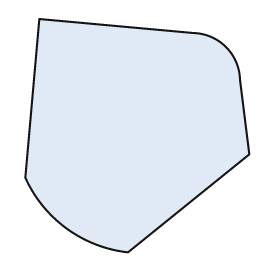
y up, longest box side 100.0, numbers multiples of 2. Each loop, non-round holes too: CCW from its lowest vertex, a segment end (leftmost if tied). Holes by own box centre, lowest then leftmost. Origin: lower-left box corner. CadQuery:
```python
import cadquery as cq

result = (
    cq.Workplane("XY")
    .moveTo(44.0, 0.0)
    .lineTo(96.0, 42.0)
    .lineTo(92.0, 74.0)
    .threePointArc((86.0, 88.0), (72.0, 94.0))
    .lineTo(6.0, 100.0)
    .lineTo(0.0, 32.0)
    .threePointArc((18.0, 10.0), (44.0, 0.0))
    .close()
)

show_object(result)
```